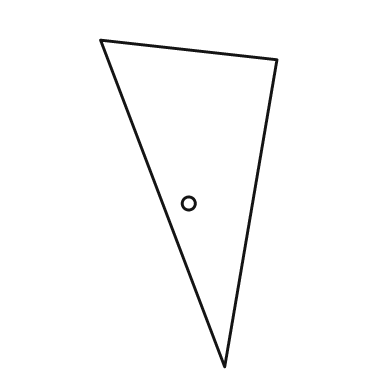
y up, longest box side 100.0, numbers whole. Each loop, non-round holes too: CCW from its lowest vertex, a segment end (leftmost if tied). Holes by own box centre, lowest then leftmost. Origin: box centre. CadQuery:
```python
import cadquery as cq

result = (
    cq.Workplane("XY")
    .moveTo(11.0, -50.0)
    .lineTo(27.0, 44.0)
    .lineTo(-27.0, 50.0)
    .close()
    .moveTo(0.0, 0.0)
    .circle(2.0)
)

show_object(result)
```